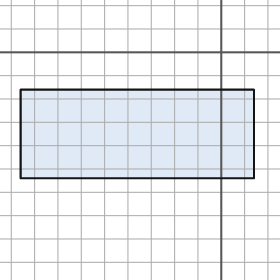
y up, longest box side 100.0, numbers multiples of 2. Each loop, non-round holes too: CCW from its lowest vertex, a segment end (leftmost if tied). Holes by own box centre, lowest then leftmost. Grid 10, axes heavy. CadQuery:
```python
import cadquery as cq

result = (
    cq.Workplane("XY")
    .moveTo(-86.0, -54.0)
    .lineTo(14.0, -54.0)
    .lineTo(14.0, -16.0)
    .lineTo(-86.0, -16.0)
    .close()
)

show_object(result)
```